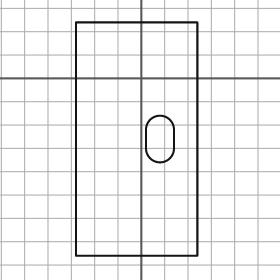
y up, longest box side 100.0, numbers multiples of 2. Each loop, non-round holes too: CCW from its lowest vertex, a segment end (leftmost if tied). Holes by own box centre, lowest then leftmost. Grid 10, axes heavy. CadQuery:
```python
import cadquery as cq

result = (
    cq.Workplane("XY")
    .moveTo(-28.0, -76.0)
    .lineTo(24.0, -76.0)
    .lineTo(24.0, 24.0)
    .lineTo(-28.0, 24.0)
    .close()
    .moveTo(2.0, -30.0)
    .threePointArc((8.0, -36.0), (14.0, -30.0))
    .lineTo(14.0, -22.0)
    .threePointArc((8.0, -16.0), (2.0, -22.0))
    .close()
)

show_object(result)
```